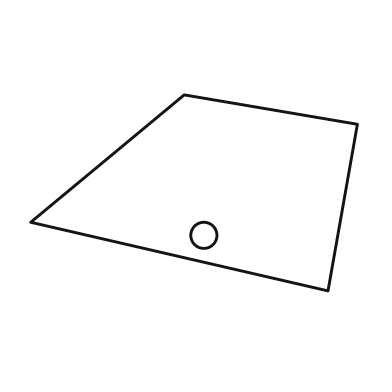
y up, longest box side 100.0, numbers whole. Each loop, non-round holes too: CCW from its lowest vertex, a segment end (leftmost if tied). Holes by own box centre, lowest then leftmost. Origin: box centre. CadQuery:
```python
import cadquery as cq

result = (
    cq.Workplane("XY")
    .moveTo(41.0, -30.0)
    .lineTo(50.0, 21.0)
    .lineTo(-3.0, 30.0)
    .lineTo(-50.0, -9.0)
    .close()
    .moveTo(3.0, -13.0)
    .circle(4.0)
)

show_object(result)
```